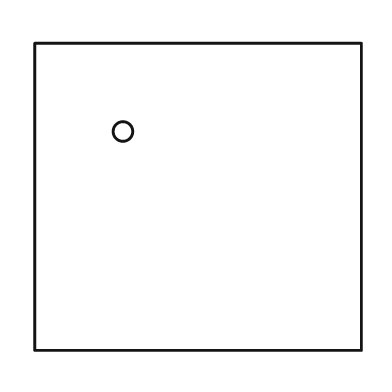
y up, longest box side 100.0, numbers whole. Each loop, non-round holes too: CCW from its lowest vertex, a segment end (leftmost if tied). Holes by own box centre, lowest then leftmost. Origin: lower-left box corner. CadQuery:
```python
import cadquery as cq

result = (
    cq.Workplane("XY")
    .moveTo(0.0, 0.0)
    .lineTo(100.0, 0.0)
    .lineTo(100.0, 94.0)
    .lineTo(0.0, 94.0)
    .close()
    .moveTo(27.0, 67.0)
    .circle(3.0)
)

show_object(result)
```